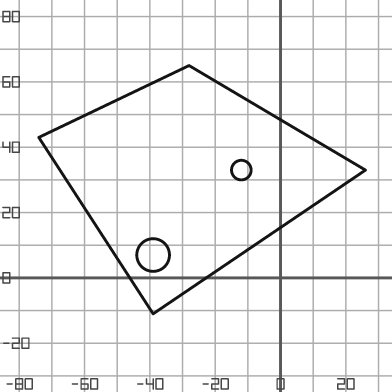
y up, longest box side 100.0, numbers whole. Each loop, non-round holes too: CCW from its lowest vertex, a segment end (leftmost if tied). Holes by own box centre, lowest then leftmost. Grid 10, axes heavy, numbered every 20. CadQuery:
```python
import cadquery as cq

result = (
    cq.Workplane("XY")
    .moveTo(-39.0, -11.0)
    .lineTo(26.0, 33.0)
    .lineTo(-28.0, 65.0)
    .lineTo(-74.0, 43.0)
    .close()
    .moveTo(-39.0, 7.0)
    .circle(5.0)
    .moveTo(-12.0, 33.0)
    .circle(3.0)
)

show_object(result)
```